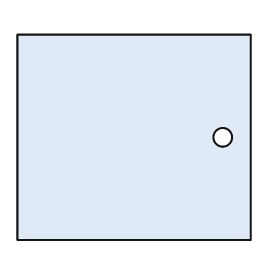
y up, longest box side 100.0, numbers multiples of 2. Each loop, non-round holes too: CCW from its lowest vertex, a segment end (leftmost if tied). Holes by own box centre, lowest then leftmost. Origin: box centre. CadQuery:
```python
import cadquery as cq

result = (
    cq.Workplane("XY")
    .moveTo(-50.0, -44.0)
    .lineTo(50.0, -44.0)
    .lineTo(50.0, 44.0)
    .lineTo(-50.0, 44.0)
    .close()
    .moveTo(38.0, 0.0)
    .circle(4.0)
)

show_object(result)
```